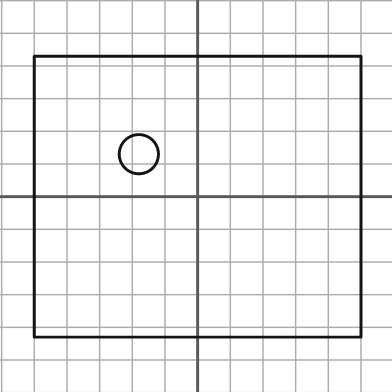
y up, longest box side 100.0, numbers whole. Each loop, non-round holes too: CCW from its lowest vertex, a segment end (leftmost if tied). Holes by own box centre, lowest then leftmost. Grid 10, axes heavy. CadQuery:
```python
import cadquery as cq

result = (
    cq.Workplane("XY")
    .moveTo(-50.0, -43.0)
    .lineTo(50.0, -43.0)
    .lineTo(50.0, 43.0)
    .lineTo(-50.0, 43.0)
    .close()
    .moveTo(-18.0, 13.0)
    .circle(6.0)
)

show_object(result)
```